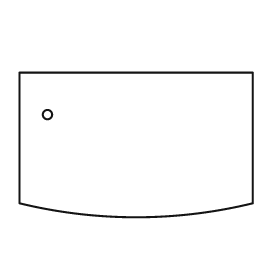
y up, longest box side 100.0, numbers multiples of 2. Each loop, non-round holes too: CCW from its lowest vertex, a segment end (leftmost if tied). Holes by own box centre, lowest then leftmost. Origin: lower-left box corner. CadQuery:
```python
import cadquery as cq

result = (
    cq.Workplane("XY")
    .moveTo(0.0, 6.0)
    .threePointArc((50.0, 0.0), (100.0, 6.0))
    .lineTo(100.0, 62.0)
    .lineTo(0.0, 62.0)
    .close()
    .moveTo(12.0, 44.0)
    .circle(2.0)
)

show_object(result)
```